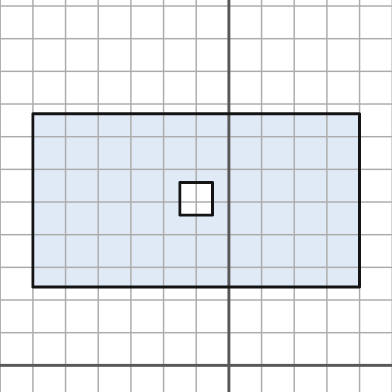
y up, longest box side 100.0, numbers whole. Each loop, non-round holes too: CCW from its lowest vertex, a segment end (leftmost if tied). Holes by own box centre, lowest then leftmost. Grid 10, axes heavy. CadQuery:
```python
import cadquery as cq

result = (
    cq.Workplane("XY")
    .moveTo(-60.0, 24.0)
    .lineTo(40.0, 24.0)
    .lineTo(40.0, 77.0)
    .lineTo(-60.0, 77.0)
    .close()
    .moveTo(-15.0, 46.0)
    .lineTo(-5.0, 46.0)
    .lineTo(-5.0, 56.0)
    .lineTo(-15.0, 56.0)
    .close()
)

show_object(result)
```